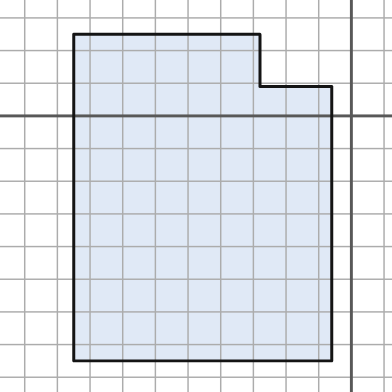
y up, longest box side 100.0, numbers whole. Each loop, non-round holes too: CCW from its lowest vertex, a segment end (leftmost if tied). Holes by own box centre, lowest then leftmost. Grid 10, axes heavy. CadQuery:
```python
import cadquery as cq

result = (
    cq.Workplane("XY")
    .moveTo(-85.0, -75.0)
    .lineTo(-6.0, -75.0)
    .lineTo(-6.0, 9.0)
    .lineTo(-28.0, 9.0)
    .lineTo(-28.0, 25.0)
    .lineTo(-85.0, 25.0)
    .close()
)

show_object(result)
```